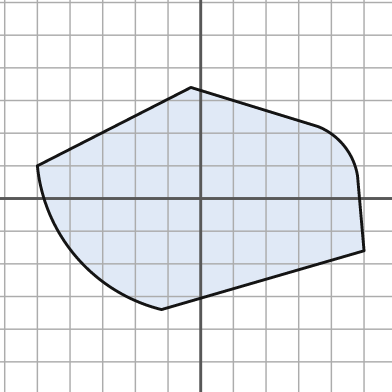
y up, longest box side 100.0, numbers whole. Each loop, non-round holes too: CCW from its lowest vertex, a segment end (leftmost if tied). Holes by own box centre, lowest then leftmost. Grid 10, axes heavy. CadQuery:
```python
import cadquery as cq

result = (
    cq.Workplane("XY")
    .moveTo(-12.0, -34.0)
    .lineTo(50.0, -16.0)
    .lineTo(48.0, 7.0)
    .threePointArc((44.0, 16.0), (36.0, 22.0))
    .lineTo(-3.0, 34.0)
    .lineTo(-50.0, 10.0)
    .threePointArc((-38.0, -18.0), (-12.0, -34.0))
    .close()
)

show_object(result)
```